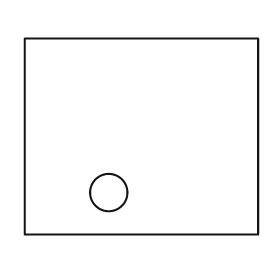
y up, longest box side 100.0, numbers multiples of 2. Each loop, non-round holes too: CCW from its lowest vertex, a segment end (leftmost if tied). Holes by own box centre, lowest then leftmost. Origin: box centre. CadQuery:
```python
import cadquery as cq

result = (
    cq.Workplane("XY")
    .moveTo(-50.0, -42.0)
    .lineTo(50.0, -42.0)
    .lineTo(50.0, 42.0)
    .lineTo(-50.0, 42.0)
    .close()
    .moveTo(-14.0, -24.0)
    .circle(8.0)
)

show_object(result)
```